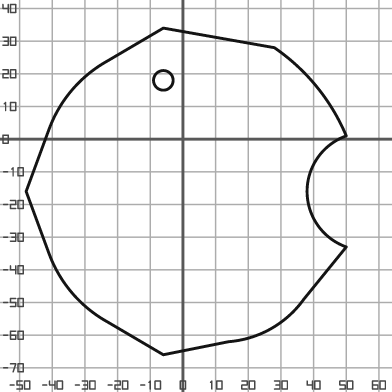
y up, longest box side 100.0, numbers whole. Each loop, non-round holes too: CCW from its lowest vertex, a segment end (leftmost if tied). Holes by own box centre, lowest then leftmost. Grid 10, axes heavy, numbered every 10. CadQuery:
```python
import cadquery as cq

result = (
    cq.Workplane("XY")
    .moveTo(-6.0, -66.0)
    .lineTo(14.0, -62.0)
    .threePointArc((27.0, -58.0), (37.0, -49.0))
    .lineTo(50.0, -33.0)
    .threePointArc((38.0, -16.0), (50.0, 1.0))
    .threePointArc((41.0, 16.0), (28.0, 28.0))
    .lineTo(-6.0, 34.0)
    .lineTo(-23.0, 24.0)
    .threePointArc((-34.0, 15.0), (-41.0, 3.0))
    .lineTo(-48.0, -16.0)
    .lineTo(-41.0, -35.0)
    .threePointArc((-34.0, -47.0), (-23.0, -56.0))
    .close()
    .moveTo(-6.0, 18.0)
    .circle(3.0)
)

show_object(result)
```